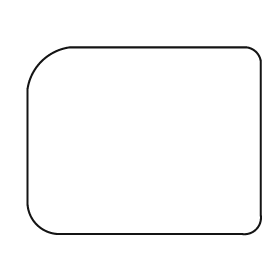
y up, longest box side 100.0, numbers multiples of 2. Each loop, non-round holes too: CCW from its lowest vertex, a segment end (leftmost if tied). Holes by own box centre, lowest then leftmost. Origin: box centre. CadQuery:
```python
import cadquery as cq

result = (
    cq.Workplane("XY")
    .moveTo(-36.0, -40.0)
    .lineTo(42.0, -40.0)
    .threePointArc((48.0, -38.0), (50.0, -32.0))
    .lineTo(50.0, 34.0)
    .threePointArc((48.0, 38.0), (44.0, 40.0))
    .lineTo(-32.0, 40.0)
    .threePointArc((-44.0, 34.0), (-50.0, 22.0))
    .lineTo(-50.0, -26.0)
    .threePointArc((-46.0, -36.0), (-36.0, -40.0))
    .close()
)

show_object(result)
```